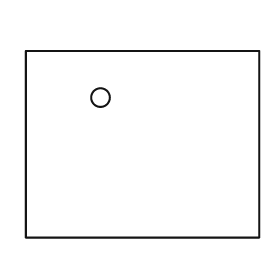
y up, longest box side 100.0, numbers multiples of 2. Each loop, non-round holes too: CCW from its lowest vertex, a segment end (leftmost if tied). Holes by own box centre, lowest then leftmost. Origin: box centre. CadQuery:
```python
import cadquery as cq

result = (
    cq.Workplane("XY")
    .moveTo(-50.0, -40.0)
    .lineTo(50.0, -40.0)
    .lineTo(50.0, 40.0)
    .lineTo(-50.0, 40.0)
    .close()
    .moveTo(-18.0, 20.0)
    .circle(4.0)
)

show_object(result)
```